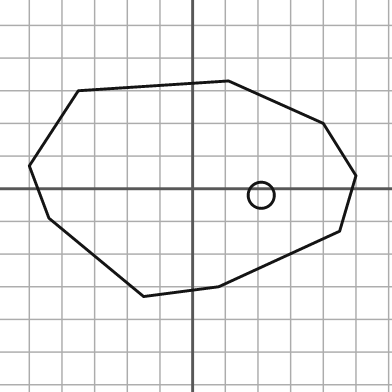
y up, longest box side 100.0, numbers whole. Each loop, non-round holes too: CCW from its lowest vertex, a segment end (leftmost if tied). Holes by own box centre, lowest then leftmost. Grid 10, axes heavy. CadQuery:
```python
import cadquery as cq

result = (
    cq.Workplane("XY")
    .moveTo(-15.0, -33.0)
    .lineTo(8.0, -30.0)
    .lineTo(45.0, -13.0)
    .lineTo(50.0, 4.0)
    .lineTo(40.0, 20.0)
    .lineTo(11.0, 33.0)
    .lineTo(-35.0, 30.0)
    .lineTo(-50.0, 7.0)
    .lineTo(-44.0, -9.0)
    .close()
    .moveTo(21.0, -2.0)
    .circle(4.0)
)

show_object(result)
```